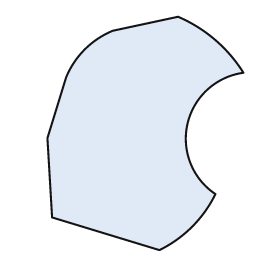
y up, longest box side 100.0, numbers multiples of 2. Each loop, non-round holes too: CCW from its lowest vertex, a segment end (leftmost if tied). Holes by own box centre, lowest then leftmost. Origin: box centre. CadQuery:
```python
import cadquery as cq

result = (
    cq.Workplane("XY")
    .moveTo(6.0, -50.0)
    .threePointArc((20.0, -40.0), (30.0, -26.0))
    .threePointArc((18.0, 4.0), (42.0, 26.0))
    .threePointArc((30.0, 40.0), (14.0, 50.0))
    .lineTo(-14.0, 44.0)
    .threePointArc((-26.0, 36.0), (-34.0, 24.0))
    .lineTo(-42.0, -2.0)
    .lineTo(-40.0, -36.0)
    .close()
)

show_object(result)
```